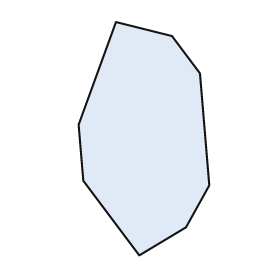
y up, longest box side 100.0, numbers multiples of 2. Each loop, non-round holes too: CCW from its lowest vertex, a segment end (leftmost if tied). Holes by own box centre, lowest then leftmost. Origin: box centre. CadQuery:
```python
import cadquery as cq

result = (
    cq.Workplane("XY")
    .moveTo(-2.0, -50.0)
    .lineTo(18.0, -38.0)
    .lineTo(28.0, -20.0)
    .lineTo(24.0, 28.0)
    .lineTo(12.0, 44.0)
    .lineTo(-12.0, 50.0)
    .lineTo(-28.0, 6.0)
    .lineTo(-26.0, -18.0)
    .close()
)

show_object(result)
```